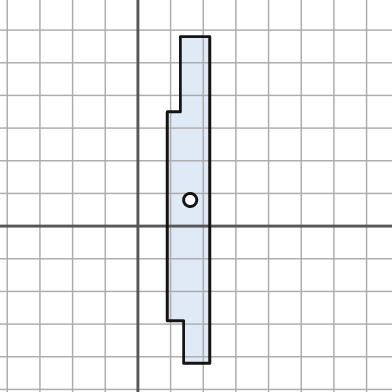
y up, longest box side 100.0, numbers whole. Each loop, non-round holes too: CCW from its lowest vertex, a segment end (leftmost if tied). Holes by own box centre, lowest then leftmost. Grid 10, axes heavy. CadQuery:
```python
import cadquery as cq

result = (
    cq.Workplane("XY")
    .moveTo(14.0, -42.0)
    .lineTo(22.0, -42.0)
    .lineTo(22.0, 58.0)
    .lineTo(13.0, 58.0)
    .lineTo(13.0, 35.0)
    .lineTo(9.0, 35.0)
    .lineTo(9.0, -29.0)
    .lineTo(14.0, -29.0)
    .close()
    .moveTo(16.0, 8.0)
    .circle(2.0)
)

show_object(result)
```